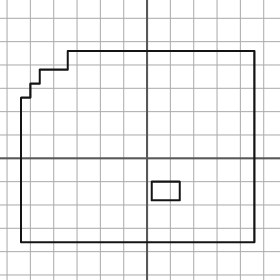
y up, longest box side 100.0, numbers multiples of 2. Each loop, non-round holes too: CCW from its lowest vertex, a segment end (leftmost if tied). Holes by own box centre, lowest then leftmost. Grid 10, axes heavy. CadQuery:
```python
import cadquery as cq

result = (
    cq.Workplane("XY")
    .moveTo(-54.0, -36.0)
    .lineTo(46.0, -36.0)
    .lineTo(46.0, 46.0)
    .lineTo(-34.0, 46.0)
    .lineTo(-34.0, 38.0)
    .lineTo(-46.0, 38.0)
    .lineTo(-46.0, 32.0)
    .lineTo(-50.0, 32.0)
    .lineTo(-50.0, 26.0)
    .lineTo(-54.0, 26.0)
    .close()
    .moveTo(2.0, -18.0)
    .lineTo(14.0, -18.0)
    .lineTo(14.0, -10.0)
    .lineTo(2.0, -10.0)
    .close()
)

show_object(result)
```